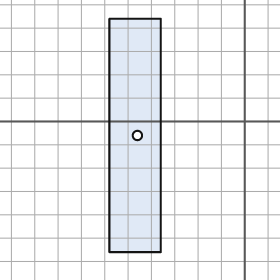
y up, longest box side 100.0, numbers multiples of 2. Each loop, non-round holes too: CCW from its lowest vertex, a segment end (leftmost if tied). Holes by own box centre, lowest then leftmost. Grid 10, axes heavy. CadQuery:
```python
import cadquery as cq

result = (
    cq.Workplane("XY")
    .moveTo(-58.0, -56.0)
    .lineTo(-36.0, -56.0)
    .lineTo(-36.0, 44.0)
    .lineTo(-58.0, 44.0)
    .close()
    .moveTo(-46.0, -6.0)
    .circle(2.0)
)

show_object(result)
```